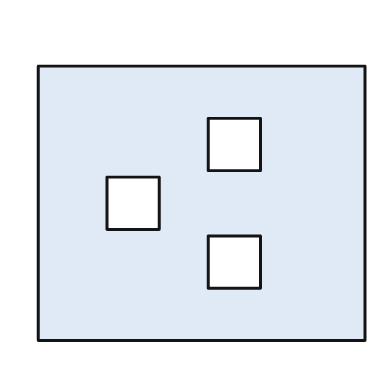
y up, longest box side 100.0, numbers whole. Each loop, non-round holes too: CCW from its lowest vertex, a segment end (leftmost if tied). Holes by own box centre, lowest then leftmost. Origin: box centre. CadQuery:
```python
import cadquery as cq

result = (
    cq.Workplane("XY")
    .moveTo(-50.0, -42.0)
    .lineTo(50.0, -42.0)
    .lineTo(50.0, 42.0)
    .lineTo(-50.0, 42.0)
    .close()
    .moveTo(2.0, -26.0)
    .lineTo(18.0, -26.0)
    .lineTo(18.0, -10.0)
    .lineTo(2.0, -10.0)
    .close()
    .moveTo(-29.0, -8.0)
    .lineTo(-13.0, -8.0)
    .lineTo(-13.0, 8.0)
    .lineTo(-29.0, 8.0)
    .close()
    .moveTo(2.0, 10.0)
    .lineTo(18.0, 10.0)
    .lineTo(18.0, 26.0)
    .lineTo(2.0, 26.0)
    .close()
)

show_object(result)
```